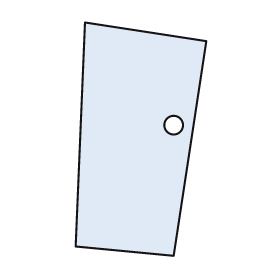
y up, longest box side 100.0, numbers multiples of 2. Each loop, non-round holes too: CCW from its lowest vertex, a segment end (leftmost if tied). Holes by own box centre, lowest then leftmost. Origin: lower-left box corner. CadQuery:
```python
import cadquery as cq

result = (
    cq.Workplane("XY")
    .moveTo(42.0, 0.0)
    .lineTo(56.0, 92.0)
    .lineTo(4.0, 100.0)
    .lineTo(0.0, 4.0)
    .close()
    .moveTo(42.0, 56.0)
    .circle(4.0)
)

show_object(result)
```